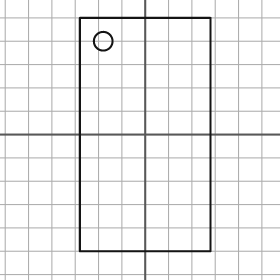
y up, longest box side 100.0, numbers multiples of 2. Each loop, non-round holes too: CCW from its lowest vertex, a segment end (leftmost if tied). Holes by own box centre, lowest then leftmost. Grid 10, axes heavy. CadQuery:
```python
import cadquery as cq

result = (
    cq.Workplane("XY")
    .moveTo(-28.0, -50.0)
    .lineTo(28.0, -50.0)
    .lineTo(28.0, 50.0)
    .lineTo(-28.0, 50.0)
    .close()
    .moveTo(-18.0, 40.0)
    .circle(4.0)
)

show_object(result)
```